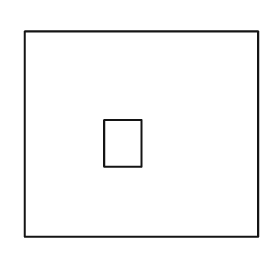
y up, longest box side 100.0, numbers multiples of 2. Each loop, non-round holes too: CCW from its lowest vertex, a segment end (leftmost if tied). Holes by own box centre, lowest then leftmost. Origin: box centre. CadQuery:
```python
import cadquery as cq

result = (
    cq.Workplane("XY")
    .moveTo(-50.0, -44.0)
    .lineTo(50.0, -44.0)
    .lineTo(50.0, 44.0)
    .lineTo(-50.0, 44.0)
    .close()
    .moveTo(-16.0, -14.0)
    .lineTo(0.0, -14.0)
    .lineTo(0.0, 6.0)
    .lineTo(-16.0, 6.0)
    .close()
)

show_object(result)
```